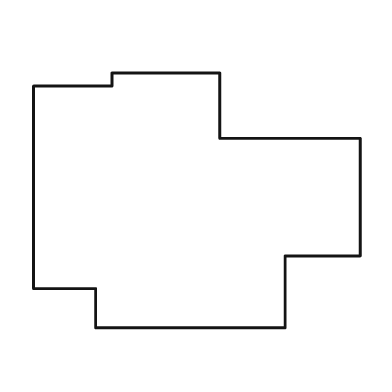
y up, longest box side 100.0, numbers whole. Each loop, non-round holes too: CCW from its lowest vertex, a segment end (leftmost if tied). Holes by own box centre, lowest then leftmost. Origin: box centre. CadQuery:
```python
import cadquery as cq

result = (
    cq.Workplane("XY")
    .moveTo(-31.0, -39.0)
    .lineTo(27.0, -39.0)
    .lineTo(27.0, -17.0)
    .lineTo(50.0, -17.0)
    .lineTo(50.0, 19.0)
    .lineTo(7.0, 19.0)
    .lineTo(7.0, 39.0)
    .lineTo(-26.0, 39.0)
    .lineTo(-26.0, 35.0)
    .lineTo(-50.0, 35.0)
    .lineTo(-50.0, -27.0)
    .lineTo(-31.0, -27.0)
    .close()
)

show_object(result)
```